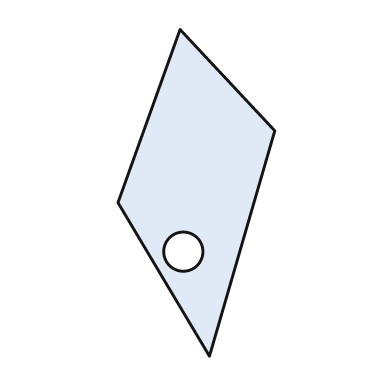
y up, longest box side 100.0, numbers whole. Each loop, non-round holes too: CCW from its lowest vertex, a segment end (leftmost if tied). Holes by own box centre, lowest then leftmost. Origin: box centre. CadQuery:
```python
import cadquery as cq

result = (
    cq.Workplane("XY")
    .moveTo(4.0, -50.0)
    .lineTo(24.0, 19.0)
    .lineTo(-5.0, 50.0)
    .lineTo(-24.0, -3.0)
    .close()
    .moveTo(-4.0, -18.0)
    .circle(6.0)
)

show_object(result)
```